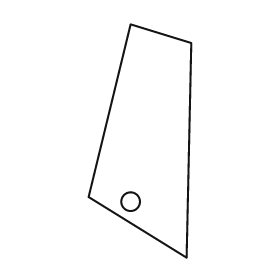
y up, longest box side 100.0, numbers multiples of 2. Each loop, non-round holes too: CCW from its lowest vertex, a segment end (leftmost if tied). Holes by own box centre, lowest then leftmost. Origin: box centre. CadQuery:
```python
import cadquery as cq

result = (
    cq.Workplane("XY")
    .moveTo(20.0, -50.0)
    .lineTo(22.0, 42.0)
    .lineTo(-4.0, 50.0)
    .lineTo(-22.0, -24.0)
    .close()
    .moveTo(-4.0, -26.0)
    .circle(4.0)
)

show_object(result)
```